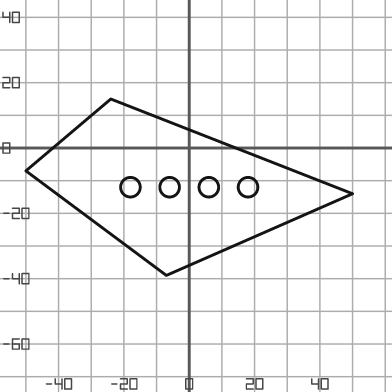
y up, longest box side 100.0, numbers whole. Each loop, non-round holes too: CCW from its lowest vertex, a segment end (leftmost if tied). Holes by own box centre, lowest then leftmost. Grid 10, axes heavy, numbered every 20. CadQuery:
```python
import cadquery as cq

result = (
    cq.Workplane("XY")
    .moveTo(-7.0, -39.0)
    .lineTo(50.0, -14.0)
    .lineTo(-24.0, 15.0)
    .lineTo(-50.0, -7.0)
    .close()
    .moveTo(-18.0, -12.0)
    .circle(3.0)
    .moveTo(-6.0, -12.0)
    .circle(3.0)
    .moveTo(6.0, -12.0)
    .circle(3.0)
    .moveTo(18.0, -12.0)
    .circle(3.0)
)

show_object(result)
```